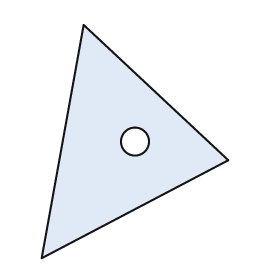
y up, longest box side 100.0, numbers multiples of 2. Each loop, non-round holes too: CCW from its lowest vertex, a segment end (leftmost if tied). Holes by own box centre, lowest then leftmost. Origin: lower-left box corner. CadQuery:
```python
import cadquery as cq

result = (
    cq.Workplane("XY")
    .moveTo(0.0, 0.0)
    .lineTo(80.0, 42.0)
    .lineTo(18.0, 100.0)
    .close()
    .moveTo(40.0, 50.0)
    .circle(6.0)
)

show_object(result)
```